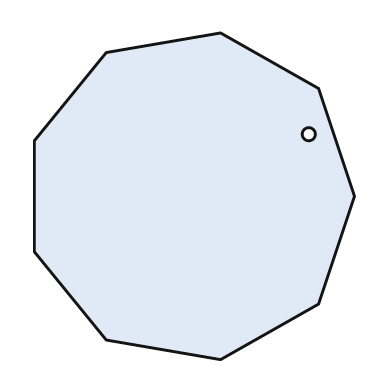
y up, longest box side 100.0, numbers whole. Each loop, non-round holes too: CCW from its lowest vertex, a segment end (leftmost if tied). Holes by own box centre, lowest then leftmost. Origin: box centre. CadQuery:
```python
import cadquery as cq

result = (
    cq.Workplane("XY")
    .moveTo(8.0, -50.0)
    .lineTo(38.0, -33.0)
    .lineTo(49.0, 0.0)
    .lineTo(38.0, 33.0)
    .lineTo(8.0, 50.0)
    .lineTo(-27.0, 44.0)
    .lineTo(-49.0, 17.0)
    .lineTo(-49.0, -17.0)
    .lineTo(-27.0, -44.0)
    .close()
    .moveTo(35.0, 19.0)
    .circle(2.0)
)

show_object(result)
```